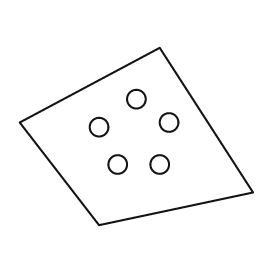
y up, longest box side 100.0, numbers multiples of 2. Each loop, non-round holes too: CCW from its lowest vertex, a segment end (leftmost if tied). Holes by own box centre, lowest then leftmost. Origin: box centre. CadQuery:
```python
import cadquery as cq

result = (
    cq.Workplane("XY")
    .moveTo(-16.0, -38.0)
    .lineTo(50.0, -24.0)
    .lineTo(10.0, 38.0)
    .lineTo(-50.0, 6.0)
    .close()
    .moveTo(-8.0, -12.0)
    .circle(4.0)
    .moveTo(10.0, -12.0)
    .circle(4.0)
    .moveTo(-16.0, 4.0)
    .circle(4.0)
    .moveTo(14.0, 6.0)
    .circle(4.0)
    .moveTo(0.0, 16.0)
    .circle(4.0)
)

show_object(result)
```